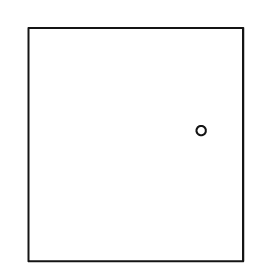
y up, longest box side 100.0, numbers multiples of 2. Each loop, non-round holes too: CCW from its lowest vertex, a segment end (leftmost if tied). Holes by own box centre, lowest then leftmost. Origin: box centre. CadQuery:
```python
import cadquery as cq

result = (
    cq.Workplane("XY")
    .moveTo(-46.0, -50.0)
    .lineTo(46.0, -50.0)
    .lineTo(46.0, 50.0)
    .lineTo(-46.0, 50.0)
    .close()
    .moveTo(28.0, 6.0)
    .circle(2.0)
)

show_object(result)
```